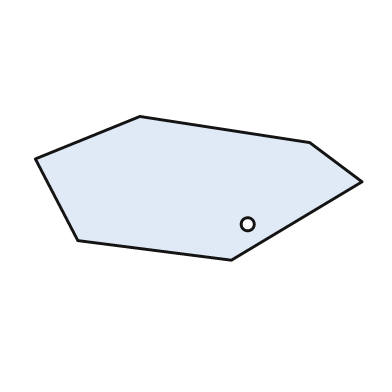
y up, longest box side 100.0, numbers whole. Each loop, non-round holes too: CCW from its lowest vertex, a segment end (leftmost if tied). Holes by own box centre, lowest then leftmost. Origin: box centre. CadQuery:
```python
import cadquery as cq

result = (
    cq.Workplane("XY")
    .moveTo(10.0, -22.0)
    .lineTo(50.0, 2.0)
    .lineTo(34.0, 14.0)
    .lineTo(-18.0, 22.0)
    .lineTo(-50.0, 9.0)
    .lineTo(-37.0, -16.0)
    .close()
    .moveTo(15.0, -11.0)
    .circle(2.0)
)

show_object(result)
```